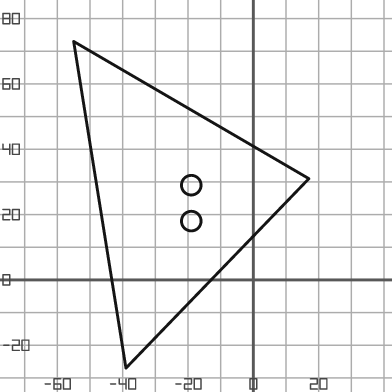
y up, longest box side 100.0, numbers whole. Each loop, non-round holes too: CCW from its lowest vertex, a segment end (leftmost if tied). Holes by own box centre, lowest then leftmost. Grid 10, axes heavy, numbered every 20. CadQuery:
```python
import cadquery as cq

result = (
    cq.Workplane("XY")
    .moveTo(-39.0, -27.0)
    .lineTo(17.0, 31.0)
    .lineTo(-55.0, 73.0)
    .close()
    .moveTo(-19.0, 18.0)
    .circle(3.0)
    .moveTo(-19.0, 29.0)
    .circle(3.0)
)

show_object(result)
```